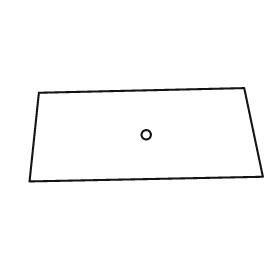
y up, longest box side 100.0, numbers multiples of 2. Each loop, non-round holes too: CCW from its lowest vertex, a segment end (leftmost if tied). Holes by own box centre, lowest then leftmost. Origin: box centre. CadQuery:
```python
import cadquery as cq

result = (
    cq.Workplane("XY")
    .moveTo(-50.0, -20.0)
    .lineTo(50.0, -18.0)
    .lineTo(42.0, 20.0)
    .lineTo(-46.0, 18.0)
    .close()
    .moveTo(0.0, 0.0)
    .circle(2.0)
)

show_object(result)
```